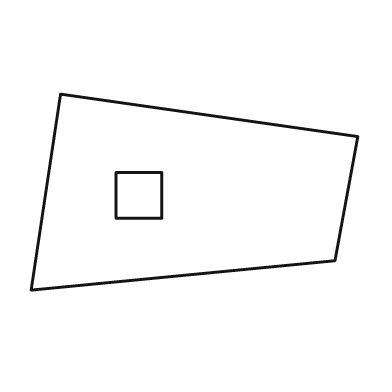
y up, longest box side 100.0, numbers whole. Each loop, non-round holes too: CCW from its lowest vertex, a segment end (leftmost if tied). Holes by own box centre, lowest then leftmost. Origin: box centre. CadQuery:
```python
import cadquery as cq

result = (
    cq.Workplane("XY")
    .moveTo(-50.0, -30.0)
    .lineTo(43.0, -21.0)
    .lineTo(50.0, 17.0)
    .lineTo(-41.0, 30.0)
    .close()
    .moveTo(-24.0, -8.0)
    .lineTo(-10.0, -8.0)
    .lineTo(-10.0, 6.0)
    .lineTo(-24.0, 6.0)
    .close()
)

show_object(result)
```